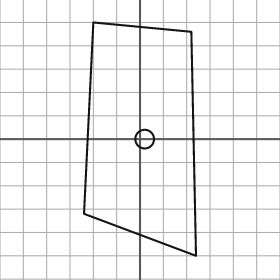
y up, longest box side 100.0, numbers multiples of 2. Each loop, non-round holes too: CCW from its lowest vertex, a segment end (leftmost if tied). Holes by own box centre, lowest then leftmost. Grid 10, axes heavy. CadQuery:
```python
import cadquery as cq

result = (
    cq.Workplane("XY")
    .moveTo(24.0, -50.0)
    .lineTo(22.0, 46.0)
    .lineTo(-20.0, 50.0)
    .lineTo(-24.0, -32.0)
    .close()
    .moveTo(2.0, 0.0)
    .circle(4.0)
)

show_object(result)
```